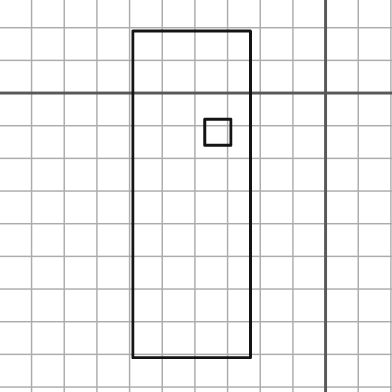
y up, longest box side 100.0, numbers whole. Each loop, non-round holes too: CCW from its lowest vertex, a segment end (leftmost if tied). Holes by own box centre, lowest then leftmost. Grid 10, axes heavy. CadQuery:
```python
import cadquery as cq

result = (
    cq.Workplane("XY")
    .moveTo(-59.0, -81.0)
    .lineTo(-23.0, -81.0)
    .lineTo(-23.0, 19.0)
    .lineTo(-59.0, 19.0)
    .close()
    .moveTo(-37.0, -16.0)
    .lineTo(-29.0, -16.0)
    .lineTo(-29.0, -8.0)
    .lineTo(-37.0, -8.0)
    .close()
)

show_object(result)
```